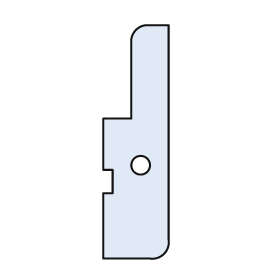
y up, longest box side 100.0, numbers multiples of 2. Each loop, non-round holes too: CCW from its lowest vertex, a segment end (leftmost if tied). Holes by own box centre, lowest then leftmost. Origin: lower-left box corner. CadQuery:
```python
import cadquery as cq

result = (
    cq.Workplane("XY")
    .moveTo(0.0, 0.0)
    .lineTo(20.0, 0.0)
    .threePointArc((26.0, 2.0), (28.0, 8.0))
    .lineTo(28.0, 100.0)
    .lineTo(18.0, 100.0)
    .threePointArc((14.0, 98.0), (12.0, 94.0))
    .lineTo(12.0, 60.0)
    .lineTo(0.0, 60.0)
    .lineTo(0.0, 38.0)
    .lineTo(4.0, 38.0)
    .lineTo(4.0, 28.0)
    .lineTo(0.0, 28.0)
    .close()
    .moveTo(16.0, 40.0)
    .circle(4.0)
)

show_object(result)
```